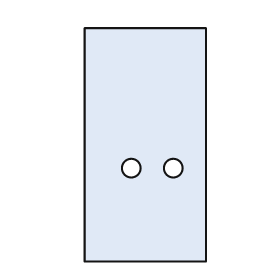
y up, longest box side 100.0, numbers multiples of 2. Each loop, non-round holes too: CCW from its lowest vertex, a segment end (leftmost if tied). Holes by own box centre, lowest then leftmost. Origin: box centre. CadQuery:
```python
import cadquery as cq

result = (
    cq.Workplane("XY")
    .moveTo(-26.0, -50.0)
    .lineTo(26.0, -50.0)
    .lineTo(26.0, 50.0)
    .lineTo(-26.0, 50.0)
    .close()
    .moveTo(-6.0, -10.0)
    .circle(4.0)
    .moveTo(12.0, -10.0)
    .circle(4.0)
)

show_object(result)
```